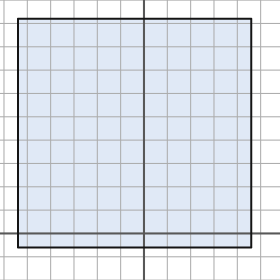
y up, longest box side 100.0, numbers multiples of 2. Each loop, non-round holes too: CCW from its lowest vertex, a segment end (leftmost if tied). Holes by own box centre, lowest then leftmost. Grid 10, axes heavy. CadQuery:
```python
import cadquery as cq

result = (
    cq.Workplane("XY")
    .moveTo(-54.0, -6.0)
    .lineTo(46.0, -6.0)
    .lineTo(46.0, 92.0)
    .lineTo(-54.0, 92.0)
    .close()
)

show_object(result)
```